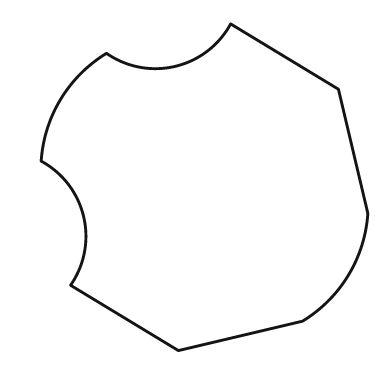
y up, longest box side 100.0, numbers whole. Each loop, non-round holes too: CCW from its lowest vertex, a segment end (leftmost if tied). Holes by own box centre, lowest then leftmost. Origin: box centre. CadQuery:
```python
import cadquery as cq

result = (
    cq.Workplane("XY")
    .moveTo(-8.0, -50.0)
    .lineTo(30.0, -41.0)
    .threePointArc((44.0, -27.0), (50.0, -8.0))
    .lineTo(41.0, 30.0)
    .lineTo(8.0, 50.0)
    .threePointArc((-9.0, 37.0), (-30.0, 41.0))
    .threePointArc((-44.0, 27.0), (-50.0, 8.0))
    .threePointArc((-37.0, -9.0), (-41.0, -30.0))
    .close()
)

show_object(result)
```